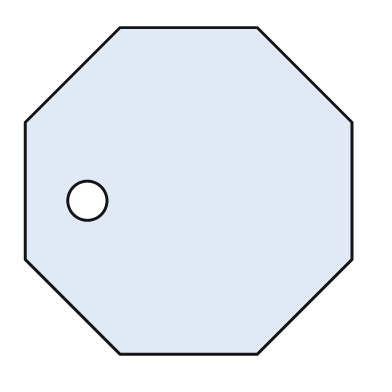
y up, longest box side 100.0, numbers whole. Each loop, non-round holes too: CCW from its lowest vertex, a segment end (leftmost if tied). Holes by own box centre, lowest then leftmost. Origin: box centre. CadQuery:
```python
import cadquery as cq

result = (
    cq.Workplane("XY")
    .moveTo(-21.0, -50.0)
    .lineTo(21.0, -50.0)
    .lineTo(50.0, -21.0)
    .lineTo(50.0, 21.0)
    .lineTo(21.0, 50.0)
    .lineTo(-21.0, 50.0)
    .lineTo(-50.0, 21.0)
    .lineTo(-50.0, -21.0)
    .close()
    .moveTo(-31.0, -3.0)
    .circle(6.0)
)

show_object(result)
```